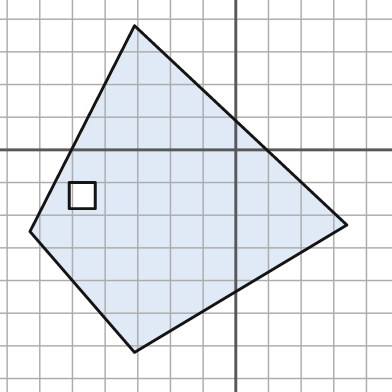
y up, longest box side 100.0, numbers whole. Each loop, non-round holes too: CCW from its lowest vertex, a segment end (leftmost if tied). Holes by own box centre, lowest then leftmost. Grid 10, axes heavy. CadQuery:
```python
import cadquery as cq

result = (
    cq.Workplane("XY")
    .moveTo(-31.0, -62.0)
    .lineTo(34.0, -23.0)
    .lineTo(-31.0, 38.0)
    .lineTo(-63.0, -25.0)
    .close()
    .moveTo(-51.0, -18.0)
    .lineTo(-43.0, -18.0)
    .lineTo(-43.0, -10.0)
    .lineTo(-51.0, -10.0)
    .close()
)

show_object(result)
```